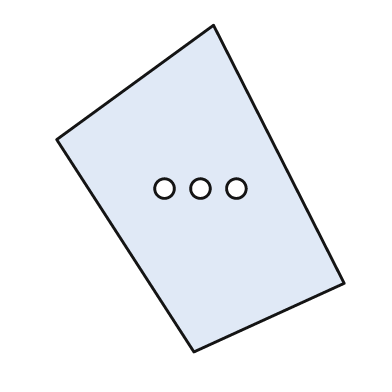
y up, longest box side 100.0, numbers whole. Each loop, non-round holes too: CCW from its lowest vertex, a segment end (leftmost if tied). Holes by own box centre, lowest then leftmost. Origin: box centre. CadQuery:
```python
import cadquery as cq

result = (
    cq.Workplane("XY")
    .moveTo(-2.0, -50.0)
    .lineTo(44.0, -29.0)
    .lineTo(4.0, 50.0)
    .lineTo(-44.0, 15.0)
    .close()
    .moveTo(-11.0, 0.0)
    .circle(3.0)
    .moveTo(0.0, 0.0)
    .circle(3.0)
    .moveTo(11.0, 0.0)
    .circle(3.0)
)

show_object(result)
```